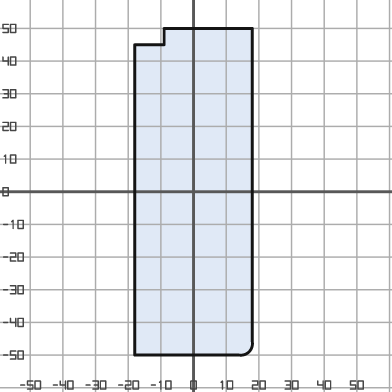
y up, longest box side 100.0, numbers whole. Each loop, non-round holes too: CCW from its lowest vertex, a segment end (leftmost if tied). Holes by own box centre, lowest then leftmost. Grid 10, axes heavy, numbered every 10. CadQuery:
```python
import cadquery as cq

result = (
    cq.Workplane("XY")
    .moveTo(-18.0, -50.0)
    .lineTo(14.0, -50.0)
    .threePointArc((17.0, -49.0), (18.0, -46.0))
    .lineTo(18.0, 50.0)
    .lineTo(-9.0, 50.0)
    .lineTo(-9.0, 45.0)
    .lineTo(-18.0, 45.0)
    .close()
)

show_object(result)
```